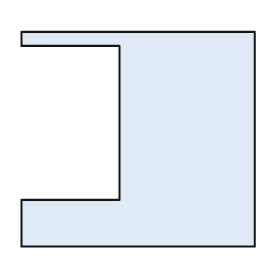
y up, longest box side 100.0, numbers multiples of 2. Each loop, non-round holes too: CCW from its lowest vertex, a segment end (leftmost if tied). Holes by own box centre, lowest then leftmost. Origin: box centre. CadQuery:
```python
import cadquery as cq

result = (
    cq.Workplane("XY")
    .moveTo(-50.0, -46.0)
    .lineTo(50.0, -46.0)
    .lineTo(50.0, 46.0)
    .lineTo(-50.0, 46.0)
    .lineTo(-50.0, 40.0)
    .lineTo(-8.0, 40.0)
    .lineTo(-8.0, -26.0)
    .lineTo(-50.0, -26.0)
    .close()
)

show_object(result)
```